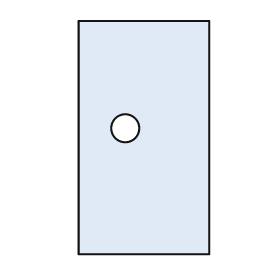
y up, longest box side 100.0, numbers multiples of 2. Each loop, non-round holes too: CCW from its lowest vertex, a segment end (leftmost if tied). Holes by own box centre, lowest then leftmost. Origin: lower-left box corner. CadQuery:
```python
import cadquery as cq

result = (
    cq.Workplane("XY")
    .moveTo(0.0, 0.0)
    .lineTo(56.0, 0.0)
    .lineTo(56.0, 100.0)
    .lineTo(0.0, 100.0)
    .close()
    .moveTo(20.0, 54.0)
    .circle(6.0)
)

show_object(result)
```